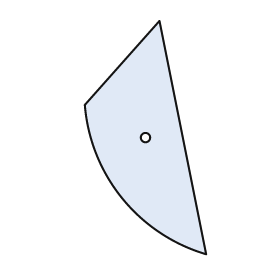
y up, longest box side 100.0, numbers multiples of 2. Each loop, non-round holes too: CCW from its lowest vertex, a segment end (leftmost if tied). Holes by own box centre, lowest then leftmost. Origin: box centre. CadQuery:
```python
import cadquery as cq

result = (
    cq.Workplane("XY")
    .moveTo(26.0, -50.0)
    .lineTo(6.0, 50.0)
    .lineTo(-26.0, 14.0)
    .threePointArc((-10.0, -26.0), (26.0, -50.0))
    .close()
    .moveTo(0.0, 0.0)
    .circle(2.0)
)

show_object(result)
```